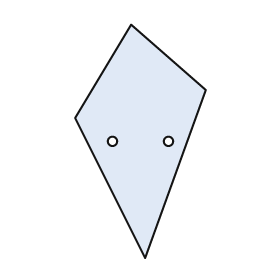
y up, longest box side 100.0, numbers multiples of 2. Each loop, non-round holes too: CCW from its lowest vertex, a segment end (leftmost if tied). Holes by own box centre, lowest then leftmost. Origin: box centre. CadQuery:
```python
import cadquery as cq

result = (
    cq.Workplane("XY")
    .moveTo(2.0, -50.0)
    .lineTo(28.0, 22.0)
    .lineTo(-4.0, 50.0)
    .lineTo(-28.0, 10.0)
    .close()
    .moveTo(-12.0, 0.0)
    .circle(2.0)
    .moveTo(12.0, 0.0)
    .circle(2.0)
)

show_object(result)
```